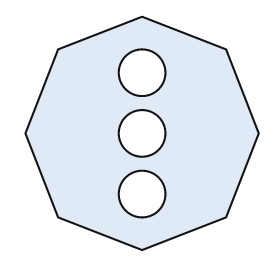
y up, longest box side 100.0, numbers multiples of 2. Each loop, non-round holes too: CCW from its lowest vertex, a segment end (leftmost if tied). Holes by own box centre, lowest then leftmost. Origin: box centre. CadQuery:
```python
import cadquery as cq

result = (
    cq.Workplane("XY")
    .moveTo(0.0, -50.0)
    .lineTo(36.0, -36.0)
    .lineTo(50.0, 0.0)
    .lineTo(36.0, 36.0)
    .lineTo(0.0, 50.0)
    .lineTo(-36.0, 36.0)
    .lineTo(-50.0, 0.0)
    .lineTo(-36.0, -36.0)
    .close()
    .moveTo(0.0, -26.0)
    .circle(10.0)
    .moveTo(0.0, 0.0)
    .circle(10.0)
    .moveTo(0.0, 26.0)
    .circle(10.0)
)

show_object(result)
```